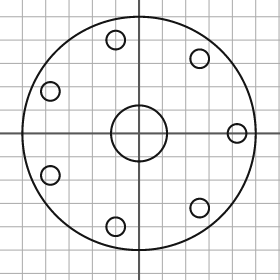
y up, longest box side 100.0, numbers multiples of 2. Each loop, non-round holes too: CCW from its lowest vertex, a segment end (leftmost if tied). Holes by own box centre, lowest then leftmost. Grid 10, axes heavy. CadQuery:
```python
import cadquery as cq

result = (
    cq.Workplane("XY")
    .moveTo(0.0, 0.0)
    .circle(50.0)
    .moveTo(-10.0, -40.0)
    .circle(4.0)
    .moveTo(26.0, -32.0)
    .circle(4.0)
    .moveTo(-38.0, -18.0)
    .circle(4.0)
    .moveTo(0.0, 0.0)
    .circle(12.0)
    .moveTo(42.0, 0.0)
    .circle(4.0)
    .moveTo(-38.0, 18.0)
    .circle(4.0)
    .moveTo(26.0, 32.0)
    .circle(4.0)
    .moveTo(-10.0, 40.0)
    .circle(4.0)
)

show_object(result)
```